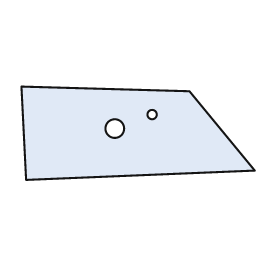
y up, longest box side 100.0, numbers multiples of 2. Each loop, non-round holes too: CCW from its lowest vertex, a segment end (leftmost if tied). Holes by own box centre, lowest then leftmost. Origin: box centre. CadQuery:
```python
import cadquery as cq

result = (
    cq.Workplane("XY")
    .moveTo(-48.0, -20.0)
    .lineTo(50.0, -16.0)
    .lineTo(22.0, 18.0)
    .lineTo(-50.0, 20.0)
    .close()
    .moveTo(-10.0, 2.0)
    .circle(4.0)
    .moveTo(6.0, 8.0)
    .circle(2.0)
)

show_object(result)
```